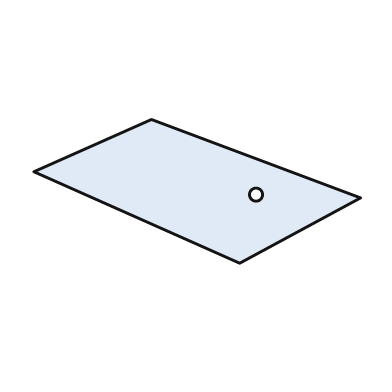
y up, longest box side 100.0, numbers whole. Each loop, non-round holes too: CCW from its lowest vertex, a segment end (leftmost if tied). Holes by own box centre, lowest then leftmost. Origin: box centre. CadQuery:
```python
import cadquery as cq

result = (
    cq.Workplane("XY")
    .moveTo(13.0, -22.0)
    .lineTo(50.0, -2.0)
    .lineTo(-14.0, 22.0)
    .lineTo(-50.0, 6.0)
    .close()
    .moveTo(18.0, -1.0)
    .circle(2.0)
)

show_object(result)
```